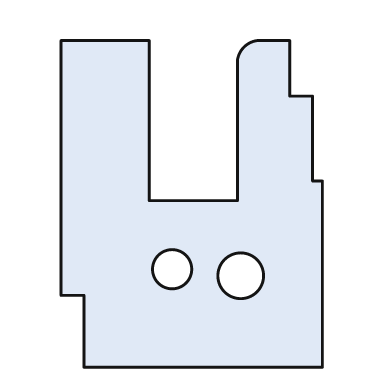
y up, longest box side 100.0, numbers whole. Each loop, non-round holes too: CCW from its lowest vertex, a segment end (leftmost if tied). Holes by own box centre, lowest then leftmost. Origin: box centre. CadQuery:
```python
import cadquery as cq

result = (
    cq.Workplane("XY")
    .moveTo(-33.0, -50.0)
    .lineTo(40.0, -50.0)
    .lineTo(40.0, 7.0)
    .lineTo(37.0, 7.0)
    .lineTo(37.0, 33.0)
    .lineTo(30.0, 33.0)
    .lineTo(30.0, 50.0)
    .lineTo(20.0, 50.0)
    .threePointArc((16.0, 48.0), (14.0, 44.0))
    .lineTo(14.0, 1.0)
    .lineTo(-13.0, 1.0)
    .lineTo(-13.0, 50.0)
    .lineTo(-40.0, 50.0)
    .lineTo(-40.0, -28.0)
    .lineTo(-33.0, -28.0)
    .close()
    .moveTo(15.0, -22.0)
    .circle(7.0)
    .moveTo(-6.0, -20.0)
    .circle(6.0)
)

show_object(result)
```